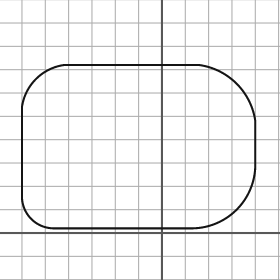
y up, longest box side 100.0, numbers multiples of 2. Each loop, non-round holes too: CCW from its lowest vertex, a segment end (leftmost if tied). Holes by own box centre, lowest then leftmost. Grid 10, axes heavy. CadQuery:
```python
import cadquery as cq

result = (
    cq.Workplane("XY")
    .moveTo(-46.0, 2.0)
    .lineTo(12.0, 2.0)
    .threePointArc((32.0, 10.0), (40.0, 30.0))
    .lineTo(40.0, 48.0)
    .threePointArc((32.0, 64.0), (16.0, 72.0))
    .lineTo(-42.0, 72.0)
    .threePointArc((-54.0, 66.0), (-60.0, 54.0))
    .lineTo(-60.0, 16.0)
    .threePointArc((-56.0, 6.0), (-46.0, 2.0))
    .close()
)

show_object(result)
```